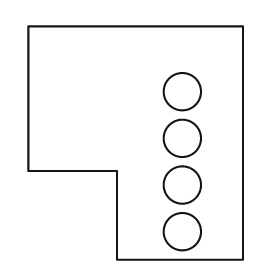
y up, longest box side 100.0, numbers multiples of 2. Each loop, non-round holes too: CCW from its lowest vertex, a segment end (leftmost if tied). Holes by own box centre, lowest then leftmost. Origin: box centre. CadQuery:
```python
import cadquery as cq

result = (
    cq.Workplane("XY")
    .moveTo(-8.0, -50.0)
    .lineTo(46.0, -50.0)
    .lineTo(46.0, 50.0)
    .lineTo(-46.0, 50.0)
    .lineTo(-46.0, -12.0)
    .lineTo(-8.0, -12.0)
    .close()
    .moveTo(20.0, -38.0)
    .circle(8.0)
    .moveTo(20.0, -18.0)
    .circle(8.0)
    .moveTo(20.0, 2.0)
    .circle(8.0)
    .moveTo(20.0, 22.0)
    .circle(8.0)
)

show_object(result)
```